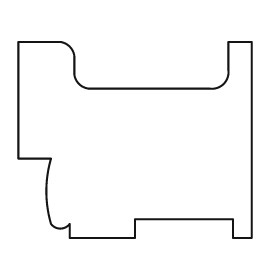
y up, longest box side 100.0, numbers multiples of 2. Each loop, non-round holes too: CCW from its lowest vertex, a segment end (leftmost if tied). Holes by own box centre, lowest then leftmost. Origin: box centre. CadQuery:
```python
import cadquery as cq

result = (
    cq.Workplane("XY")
    .moveTo(-28.0, -42.0)
    .lineTo(0.0, -42.0)
    .lineTo(0.0, -34.0)
    .lineTo(42.0, -34.0)
    .lineTo(42.0, -42.0)
    .lineTo(50.0, -42.0)
    .lineTo(50.0, 42.0)
    .lineTo(40.0, 42.0)
    .lineTo(40.0, 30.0)
    .threePointArc((38.0, 24.0), (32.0, 22.0))
    .lineTo(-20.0, 22.0)
    .threePointArc((-24.0, 24.0), (-26.0, 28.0))
    .lineTo(-26.0, 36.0)
    .threePointArc((-28.0, 40.0), (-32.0, 42.0))
    .lineTo(-50.0, 42.0)
    .lineTo(-50.0, -8.0)
    .lineTo(-36.0, -8.0)
    .threePointArc((-38.0, -22.0), (-36.0, -36.0))
    .threePointArc((-32.0, -38.0), (-28.0, -36.0))
    .close()
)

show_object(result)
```